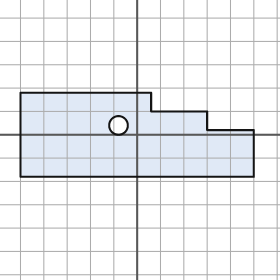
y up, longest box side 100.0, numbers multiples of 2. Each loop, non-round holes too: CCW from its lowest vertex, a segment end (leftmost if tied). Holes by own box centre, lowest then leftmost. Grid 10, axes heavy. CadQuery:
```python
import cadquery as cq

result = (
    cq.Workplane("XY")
    .moveTo(-50.0, -18.0)
    .lineTo(50.0, -18.0)
    .lineTo(50.0, 2.0)
    .lineTo(30.0, 2.0)
    .lineTo(30.0, 10.0)
    .lineTo(6.0, 10.0)
    .lineTo(6.0, 18.0)
    .lineTo(-50.0, 18.0)
    .close()
    .moveTo(-8.0, 4.0)
    .circle(4.0)
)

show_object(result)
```